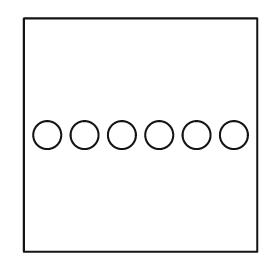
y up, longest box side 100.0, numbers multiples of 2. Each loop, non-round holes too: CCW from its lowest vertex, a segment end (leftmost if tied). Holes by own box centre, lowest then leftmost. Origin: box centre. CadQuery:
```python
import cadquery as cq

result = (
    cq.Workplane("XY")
    .moveTo(-50.0, -50.0)
    .lineTo(50.0, -50.0)
    .lineTo(50.0, 50.0)
    .lineTo(-50.0, 50.0)
    .close()
    .moveTo(-40.0, 0.0)
    .circle(6.0)
    .moveTo(-24.0, 0.0)
    .circle(6.0)
    .moveTo(-8.0, 0.0)
    .circle(6.0)
    .moveTo(8.0, 0.0)
    .circle(6.0)
    .moveTo(24.0, 0.0)
    .circle(6.0)
    .moveTo(40.0, 0.0)
    .circle(6.0)
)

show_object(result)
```